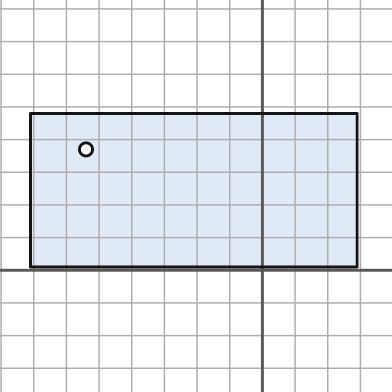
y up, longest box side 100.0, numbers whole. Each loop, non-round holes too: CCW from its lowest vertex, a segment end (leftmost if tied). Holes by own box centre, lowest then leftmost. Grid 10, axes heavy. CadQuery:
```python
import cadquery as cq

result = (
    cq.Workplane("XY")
    .moveTo(-71.0, 1.0)
    .lineTo(29.0, 1.0)
    .lineTo(29.0, 48.0)
    .lineTo(-71.0, 48.0)
    .close()
    .moveTo(-54.0, 37.0)
    .circle(2.0)
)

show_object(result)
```